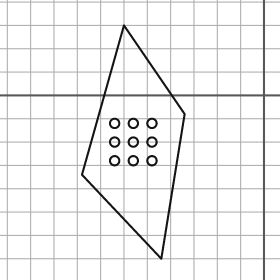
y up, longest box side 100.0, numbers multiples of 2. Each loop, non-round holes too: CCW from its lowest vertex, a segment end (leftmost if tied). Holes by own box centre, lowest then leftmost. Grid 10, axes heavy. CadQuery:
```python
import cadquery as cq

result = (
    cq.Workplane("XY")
    .moveTo(-44.0, -70.0)
    .lineTo(-34.0, -8.0)
    .lineTo(-60.0, 30.0)
    .lineTo(-78.0, -34.0)
    .close()
    .moveTo(-64.0, -28.0)
    .circle(2.0)
    .moveTo(-56.0, -28.0)
    .circle(2.0)
    .moveTo(-48.0, -28.0)
    .circle(2.0)
    .moveTo(-64.0, -20.0)
    .circle(2.0)
    .moveTo(-56.0, -20.0)
    .circle(2.0)
    .moveTo(-48.0, -20.0)
    .circle(2.0)
    .moveTo(-64.0, -12.0)
    .circle(2.0)
    .moveTo(-56.0, -12.0)
    .circle(2.0)
    .moveTo(-48.0, -12.0)
    .circle(2.0)
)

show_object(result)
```